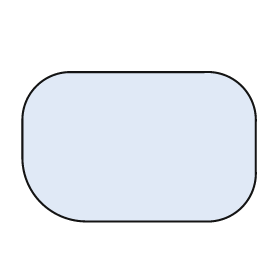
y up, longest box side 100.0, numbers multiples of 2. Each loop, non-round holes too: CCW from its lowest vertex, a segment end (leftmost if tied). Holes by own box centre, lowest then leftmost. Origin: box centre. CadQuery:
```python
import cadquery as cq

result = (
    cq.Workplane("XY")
    .moveTo(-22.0, -32.0)
    .lineTo(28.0, -32.0)
    .threePointArc((44.0, -26.0), (50.0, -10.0))
    .lineTo(50.0, 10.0)
    .threePointArc((44.0, 26.0), (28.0, 32.0))
    .lineTo(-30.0, 32.0)
    .threePointArc((-44.0, 26.0), (-50.0, 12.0))
    .lineTo(-50.0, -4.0)
    .threePointArc((-42.0, -24.0), (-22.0, -32.0))
    .close()
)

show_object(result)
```